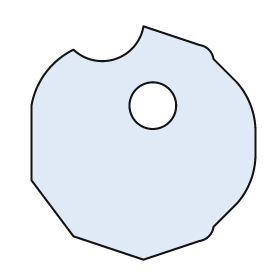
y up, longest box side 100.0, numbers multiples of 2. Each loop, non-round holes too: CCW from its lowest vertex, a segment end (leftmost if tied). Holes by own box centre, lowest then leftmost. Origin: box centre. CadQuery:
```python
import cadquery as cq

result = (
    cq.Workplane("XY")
    .moveTo(0.0, -50.0)
    .lineTo(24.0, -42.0)
    .threePointArc((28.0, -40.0), (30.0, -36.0))
    .lineTo(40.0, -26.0)
    .threePointArc((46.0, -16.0), (48.0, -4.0))
    .lineTo(48.0, 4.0)
    .threePointArc((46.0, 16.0), (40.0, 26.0))
    .lineTo(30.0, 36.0)
    .threePointArc((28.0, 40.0), (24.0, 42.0))
    .lineTo(0.0, 50.0)
    .threePointArc((-12.0, 36.0), (-30.0, 40.0))
    .threePointArc((-42.0, 30.0), (-48.0, 16.0))
    .lineTo(-48.0, -16.0)
    .lineTo(-30.0, -40.0)
    .close()
    .moveTo(4.0, 16.0)
    .circle(10.0)
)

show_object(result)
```